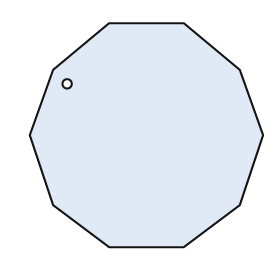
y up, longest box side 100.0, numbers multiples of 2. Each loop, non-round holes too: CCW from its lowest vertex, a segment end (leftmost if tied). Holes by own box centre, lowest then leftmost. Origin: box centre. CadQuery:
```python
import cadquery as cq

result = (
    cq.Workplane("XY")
    .moveTo(-16.0, -48.0)
    .lineTo(16.0, -48.0)
    .lineTo(40.0, -30.0)
    .lineTo(50.0, 0.0)
    .lineTo(40.0, 28.0)
    .lineTo(16.0, 48.0)
    .lineTo(-16.0, 48.0)
    .lineTo(-40.0, 28.0)
    .lineTo(-50.0, 0.0)
    .lineTo(-40.0, -30.0)
    .close()
    .moveTo(-34.0, 22.0)
    .circle(2.0)
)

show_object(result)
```